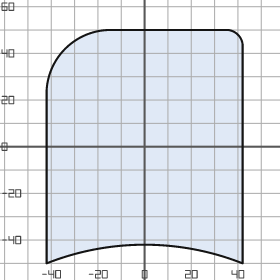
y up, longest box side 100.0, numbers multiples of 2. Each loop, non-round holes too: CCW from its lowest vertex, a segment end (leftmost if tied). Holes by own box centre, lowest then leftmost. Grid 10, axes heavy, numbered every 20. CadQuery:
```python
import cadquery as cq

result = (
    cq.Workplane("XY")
    .moveTo(-42.0, -50.0)
    .threePointArc((0.0, -42.0), (42.0, -50.0))
    .lineTo(42.0, 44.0)
    .threePointArc((40.0, 48.0), (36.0, 50.0))
    .lineTo(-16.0, 50.0)
    .threePointArc((-34.0, 42.0), (-42.0, 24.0))
    .close()
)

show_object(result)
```